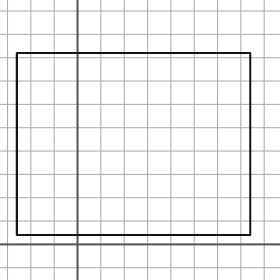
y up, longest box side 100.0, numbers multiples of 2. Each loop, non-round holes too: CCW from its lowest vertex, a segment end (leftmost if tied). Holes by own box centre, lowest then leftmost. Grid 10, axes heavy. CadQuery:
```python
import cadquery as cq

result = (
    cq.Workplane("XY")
    .moveTo(-26.0, 4.0)
    .lineTo(74.0, 4.0)
    .lineTo(74.0, 82.0)
    .lineTo(-26.0, 82.0)
    .close()
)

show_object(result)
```